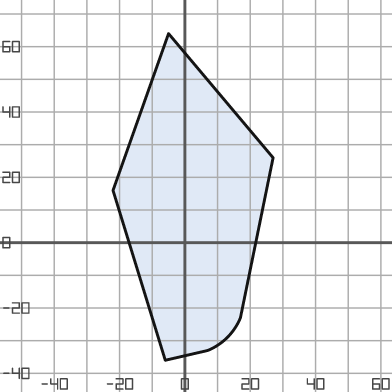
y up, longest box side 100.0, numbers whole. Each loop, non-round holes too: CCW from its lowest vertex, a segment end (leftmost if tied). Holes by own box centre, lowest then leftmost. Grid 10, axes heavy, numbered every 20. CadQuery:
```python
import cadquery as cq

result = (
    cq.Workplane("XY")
    .moveTo(-6.0, -36.0)
    .lineTo(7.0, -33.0)
    .threePointArc((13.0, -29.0), (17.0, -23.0))
    .lineTo(27.0, 26.0)
    .lineTo(-5.0, 64.0)
    .lineTo(-22.0, 16.0)
    .close()
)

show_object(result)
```